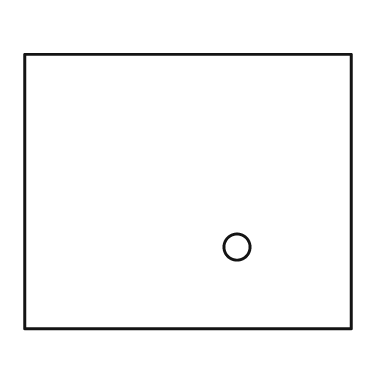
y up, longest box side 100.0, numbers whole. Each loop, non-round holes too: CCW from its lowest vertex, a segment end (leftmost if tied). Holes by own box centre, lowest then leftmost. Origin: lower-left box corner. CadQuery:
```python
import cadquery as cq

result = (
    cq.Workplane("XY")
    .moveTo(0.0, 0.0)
    .lineTo(100.0, 0.0)
    .lineTo(100.0, 84.0)
    .lineTo(0.0, 84.0)
    .close()
    .moveTo(65.0, 25.0)
    .circle(4.0)
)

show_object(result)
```